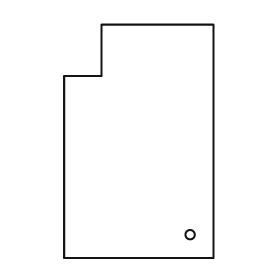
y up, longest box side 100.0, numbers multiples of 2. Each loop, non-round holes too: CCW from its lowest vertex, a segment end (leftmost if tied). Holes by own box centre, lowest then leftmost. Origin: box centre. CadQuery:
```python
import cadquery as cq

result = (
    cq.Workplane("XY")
    .moveTo(-32.0, -50.0)
    .lineTo(32.0, -50.0)
    .lineTo(32.0, 50.0)
    .lineTo(-16.0, 50.0)
    .lineTo(-16.0, 28.0)
    .lineTo(-32.0, 28.0)
    .close()
    .moveTo(22.0, -40.0)
    .circle(2.0)
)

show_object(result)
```